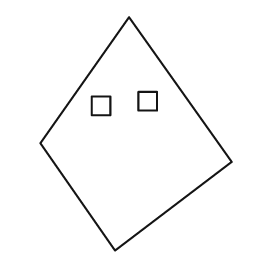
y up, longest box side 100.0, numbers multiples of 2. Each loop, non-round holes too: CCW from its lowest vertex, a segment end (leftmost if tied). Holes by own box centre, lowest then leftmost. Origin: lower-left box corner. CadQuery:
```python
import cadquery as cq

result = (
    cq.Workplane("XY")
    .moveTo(32.0, 0.0)
    .lineTo(82.0, 38.0)
    .lineTo(38.0, 100.0)
    .lineTo(0.0, 46.0)
    .close()
    .moveTo(22.0, 58.0)
    .lineTo(30.0, 58.0)
    .lineTo(30.0, 66.0)
    .lineTo(22.0, 66.0)
    .close()
    .moveTo(42.0, 60.0)
    .lineTo(50.0, 60.0)
    .lineTo(50.0, 68.0)
    .lineTo(42.0, 68.0)
    .close()
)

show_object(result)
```